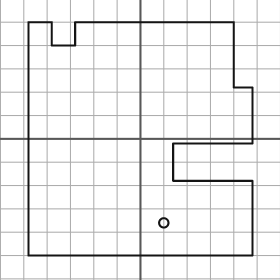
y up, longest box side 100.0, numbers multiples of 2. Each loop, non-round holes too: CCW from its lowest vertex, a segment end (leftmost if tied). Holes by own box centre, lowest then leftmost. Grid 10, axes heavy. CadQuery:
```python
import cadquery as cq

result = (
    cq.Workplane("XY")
    .moveTo(-48.0, -50.0)
    .lineTo(48.0, -50.0)
    .lineTo(48.0, -18.0)
    .lineTo(14.0, -18.0)
    .lineTo(14.0, -2.0)
    .lineTo(48.0, -2.0)
    .lineTo(48.0, 22.0)
    .lineTo(40.0, 22.0)
    .lineTo(40.0, 50.0)
    .lineTo(-28.0, 50.0)
    .lineTo(-28.0, 40.0)
    .lineTo(-38.0, 40.0)
    .lineTo(-38.0, 50.0)
    .lineTo(-48.0, 50.0)
    .close()
    .moveTo(10.0, -36.0)
    .circle(2.0)
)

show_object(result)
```